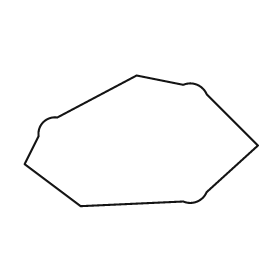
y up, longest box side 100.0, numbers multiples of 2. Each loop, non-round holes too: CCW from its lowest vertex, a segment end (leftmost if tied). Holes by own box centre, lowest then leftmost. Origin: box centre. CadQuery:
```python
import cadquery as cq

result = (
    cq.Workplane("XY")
    .moveTo(-26.0, -28.0)
    .lineTo(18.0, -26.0)
    .threePointArc((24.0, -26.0), (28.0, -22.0))
    .lineTo(50.0, -2.0)
    .lineTo(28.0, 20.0)
    .threePointArc((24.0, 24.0), (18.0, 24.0))
    .lineTo(-2.0, 28.0)
    .lineTo(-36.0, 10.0)
    .threePointArc((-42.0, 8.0), (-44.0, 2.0))
    .lineTo(-50.0, -10.0)
    .close()
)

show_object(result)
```